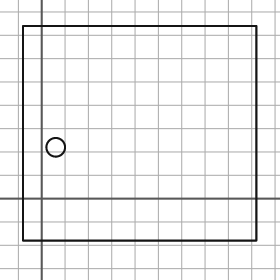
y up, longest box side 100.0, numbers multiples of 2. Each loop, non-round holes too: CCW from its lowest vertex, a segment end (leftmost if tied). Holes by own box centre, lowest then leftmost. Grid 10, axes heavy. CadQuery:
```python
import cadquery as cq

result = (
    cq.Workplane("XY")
    .moveTo(-8.0, -18.0)
    .lineTo(92.0, -18.0)
    .lineTo(92.0, 74.0)
    .lineTo(-8.0, 74.0)
    .close()
    .moveTo(6.0, 22.0)
    .circle(4.0)
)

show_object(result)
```